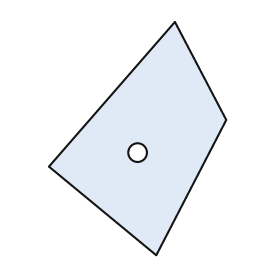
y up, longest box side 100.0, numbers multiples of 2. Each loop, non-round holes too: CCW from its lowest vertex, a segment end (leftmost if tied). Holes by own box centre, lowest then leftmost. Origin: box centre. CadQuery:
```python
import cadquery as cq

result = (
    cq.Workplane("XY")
    .moveTo(8.0, -50.0)
    .lineTo(38.0, 8.0)
    .lineTo(16.0, 50.0)
    .lineTo(-38.0, -12.0)
    .close()
    .moveTo(0.0, -6.0)
    .circle(4.0)
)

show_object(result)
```